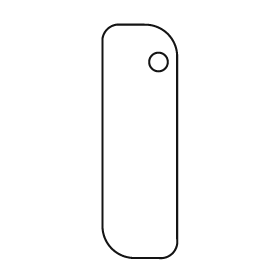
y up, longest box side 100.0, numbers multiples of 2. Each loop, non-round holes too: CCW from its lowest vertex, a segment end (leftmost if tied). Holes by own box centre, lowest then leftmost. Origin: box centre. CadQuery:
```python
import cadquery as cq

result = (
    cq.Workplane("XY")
    .moveTo(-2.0, -50.0)
    .lineTo(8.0, -50.0)
    .threePointArc((14.0, -48.0), (16.0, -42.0))
    .lineTo(16.0, 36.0)
    .threePointArc((12.0, 46.0), (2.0, 50.0))
    .lineTo(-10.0, 50.0)
    .threePointArc((-14.0, 48.0), (-16.0, 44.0))
    .lineTo(-16.0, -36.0)
    .threePointArc((-12.0, -46.0), (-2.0, -50.0))
    .close()
    .moveTo(8.0, 34.0)
    .circle(4.0)
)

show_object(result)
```